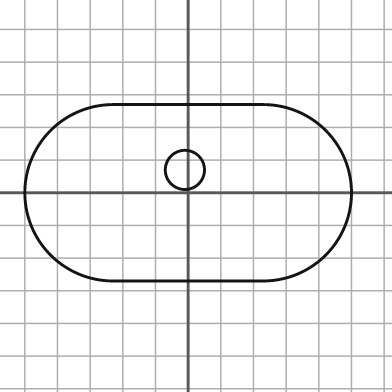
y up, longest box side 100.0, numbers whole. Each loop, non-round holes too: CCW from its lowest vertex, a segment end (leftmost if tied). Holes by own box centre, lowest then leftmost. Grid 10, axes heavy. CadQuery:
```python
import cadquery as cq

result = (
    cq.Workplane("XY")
    .moveTo(-23.0, -27.0)
    .lineTo(23.0, -27.0)
    .threePointArc((50.0, 0.0), (23.0, 27.0))
    .lineTo(-23.0, 27.0)
    .threePointArc((-50.0, 0.0), (-23.0, -27.0))
    .close()
    .moveTo(-1.0, 7.0)
    .circle(6.0)
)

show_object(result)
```